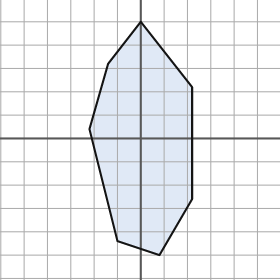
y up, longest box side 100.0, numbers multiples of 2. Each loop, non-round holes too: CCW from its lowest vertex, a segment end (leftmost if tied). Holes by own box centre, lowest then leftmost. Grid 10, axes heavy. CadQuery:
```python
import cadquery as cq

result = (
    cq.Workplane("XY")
    .moveTo(8.0, -50.0)
    .lineTo(22.0, -26.0)
    .lineTo(22.0, 22.0)
    .lineTo(0.0, 50.0)
    .lineTo(-14.0, 32.0)
    .lineTo(-22.0, 4.0)
    .lineTo(-10.0, -44.0)
    .close()
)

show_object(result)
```